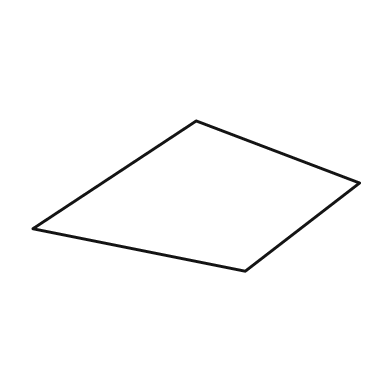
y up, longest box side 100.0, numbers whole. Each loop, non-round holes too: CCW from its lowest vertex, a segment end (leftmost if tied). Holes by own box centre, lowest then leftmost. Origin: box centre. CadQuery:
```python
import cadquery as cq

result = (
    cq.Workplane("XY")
    .moveTo(15.0, -23.0)
    .lineTo(50.0, 4.0)
    .lineTo(0.0, 23.0)
    .lineTo(-50.0, -10.0)
    .close()
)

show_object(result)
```